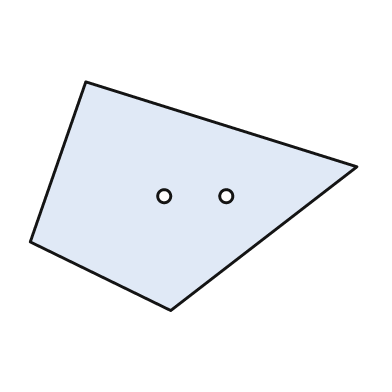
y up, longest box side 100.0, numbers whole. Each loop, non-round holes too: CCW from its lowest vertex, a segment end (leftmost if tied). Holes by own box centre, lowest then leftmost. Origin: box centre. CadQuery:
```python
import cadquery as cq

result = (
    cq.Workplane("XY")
    .moveTo(-7.0, -35.0)
    .lineTo(50.0, 9.0)
    .lineTo(-33.0, 35.0)
    .lineTo(-50.0, -14.0)
    .close()
    .moveTo(-9.0, 0.0)
    .circle(2.0)
    .moveTo(10.0, 0.0)
    .circle(2.0)
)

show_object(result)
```